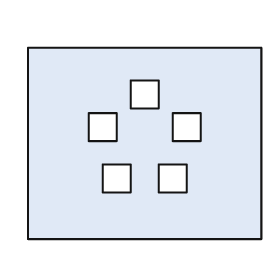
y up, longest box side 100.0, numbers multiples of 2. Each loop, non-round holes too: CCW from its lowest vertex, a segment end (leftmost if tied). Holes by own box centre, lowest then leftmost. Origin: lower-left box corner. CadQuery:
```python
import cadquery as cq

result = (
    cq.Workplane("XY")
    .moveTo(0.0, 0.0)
    .lineTo(100.0, 0.0)
    .lineTo(100.0, 82.0)
    .lineTo(0.0, 82.0)
    .close()
    .moveTo(32.0, 20.0)
    .lineTo(44.0, 20.0)
    .lineTo(44.0, 32.0)
    .lineTo(32.0, 32.0)
    .close()
    .moveTo(56.0, 20.0)
    .lineTo(68.0, 20.0)
    .lineTo(68.0, 32.0)
    .lineTo(56.0, 32.0)
    .close()
    .moveTo(26.0, 42.0)
    .lineTo(38.0, 42.0)
    .lineTo(38.0, 54.0)
    .lineTo(26.0, 54.0)
    .close()
    .moveTo(62.0, 42.0)
    .lineTo(74.0, 42.0)
    .lineTo(74.0, 54.0)
    .lineTo(62.0, 54.0)
    .close()
    .moveTo(44.0, 56.0)
    .lineTo(56.0, 56.0)
    .lineTo(56.0, 68.0)
    .lineTo(44.0, 68.0)
    .close()
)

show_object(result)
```